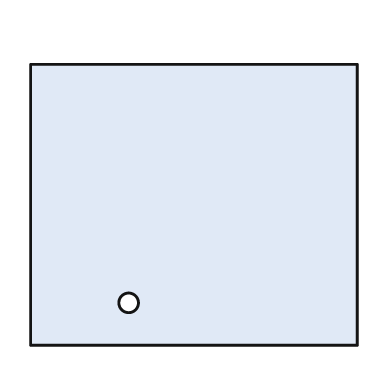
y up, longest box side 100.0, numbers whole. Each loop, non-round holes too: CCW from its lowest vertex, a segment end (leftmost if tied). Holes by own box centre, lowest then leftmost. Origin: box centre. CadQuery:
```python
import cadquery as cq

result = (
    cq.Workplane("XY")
    .moveTo(-50.0, -43.0)
    .lineTo(50.0, -43.0)
    .lineTo(50.0, 43.0)
    .lineTo(-50.0, 43.0)
    .close()
    .moveTo(-20.0, -30.0)
    .circle(3.0)
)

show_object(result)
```